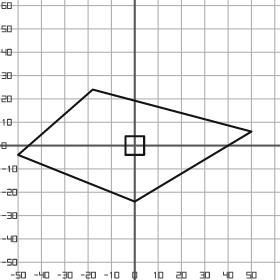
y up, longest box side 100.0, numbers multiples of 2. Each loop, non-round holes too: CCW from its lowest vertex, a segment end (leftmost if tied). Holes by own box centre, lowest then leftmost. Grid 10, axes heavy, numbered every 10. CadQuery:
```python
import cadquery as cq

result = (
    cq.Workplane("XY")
    .moveTo(0.0, -24.0)
    .lineTo(50.0, 6.0)
    .lineTo(-18.0, 24.0)
    .lineTo(-50.0, -4.0)
    .close()
    .moveTo(-4.0, -4.0)
    .lineTo(4.0, -4.0)
    .lineTo(4.0, 4.0)
    .lineTo(-4.0, 4.0)
    .close()
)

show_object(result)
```